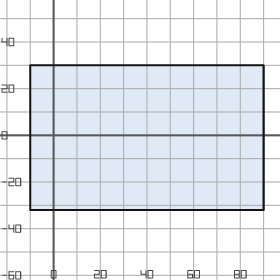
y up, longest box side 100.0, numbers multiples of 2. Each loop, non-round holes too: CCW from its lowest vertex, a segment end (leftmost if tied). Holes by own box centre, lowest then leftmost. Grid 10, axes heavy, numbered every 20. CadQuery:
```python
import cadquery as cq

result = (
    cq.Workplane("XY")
    .moveTo(-10.0, -32.0)
    .lineTo(90.0, -32.0)
    .lineTo(90.0, 30.0)
    .lineTo(-10.0, 30.0)
    .close()
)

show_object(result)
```